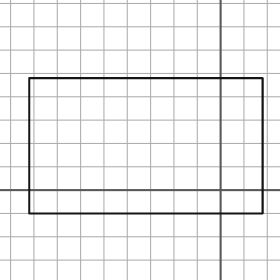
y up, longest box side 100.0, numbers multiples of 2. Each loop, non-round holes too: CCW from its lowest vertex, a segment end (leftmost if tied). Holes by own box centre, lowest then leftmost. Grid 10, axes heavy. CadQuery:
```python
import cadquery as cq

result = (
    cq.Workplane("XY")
    .moveTo(-82.0, -10.0)
    .lineTo(18.0, -10.0)
    .lineTo(18.0, 48.0)
    .lineTo(-82.0, 48.0)
    .close()
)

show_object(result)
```